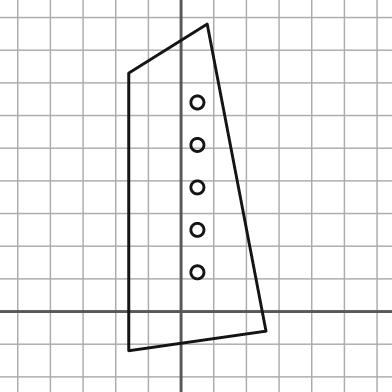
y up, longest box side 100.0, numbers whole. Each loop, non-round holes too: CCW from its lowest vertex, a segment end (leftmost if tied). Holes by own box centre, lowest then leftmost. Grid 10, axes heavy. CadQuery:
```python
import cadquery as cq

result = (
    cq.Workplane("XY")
    .moveTo(-16.0, -12.0)
    .lineTo(26.0, -6.0)
    .lineTo(8.0, 88.0)
    .lineTo(-16.0, 73.0)
    .close()
    .moveTo(5.0, 12.0)
    .circle(2.0)
    .moveTo(5.0, 25.0)
    .circle(2.0)
    .moveTo(5.0, 38.0)
    .circle(2.0)
    .moveTo(5.0, 51.0)
    .circle(2.0)
    .moveTo(5.0, 64.0)
    .circle(2.0)
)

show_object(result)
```